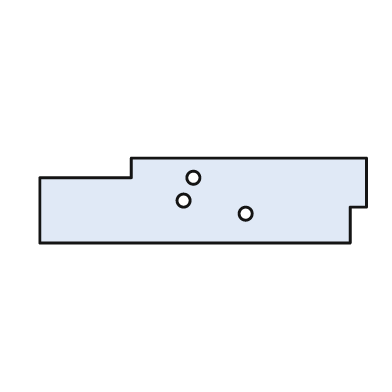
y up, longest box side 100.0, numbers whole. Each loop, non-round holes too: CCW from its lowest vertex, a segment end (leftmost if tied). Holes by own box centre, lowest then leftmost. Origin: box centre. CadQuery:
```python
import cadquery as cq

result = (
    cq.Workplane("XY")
    .moveTo(-50.0, -13.0)
    .lineTo(45.0, -13.0)
    .lineTo(45.0, -2.0)
    .lineTo(50.0, -2.0)
    .lineTo(50.0, 13.0)
    .lineTo(-22.0, 13.0)
    .lineTo(-22.0, 7.0)
    .lineTo(-50.0, 7.0)
    .close()
    .moveTo(13.0, -4.0)
    .circle(2.0)
    .moveTo(-6.0, 0.0)
    .circle(2.0)
    .moveTo(-3.0, 7.0)
    .circle(2.0)
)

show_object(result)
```